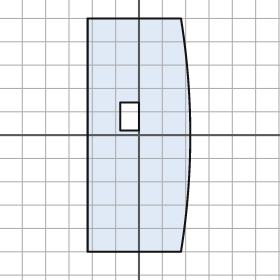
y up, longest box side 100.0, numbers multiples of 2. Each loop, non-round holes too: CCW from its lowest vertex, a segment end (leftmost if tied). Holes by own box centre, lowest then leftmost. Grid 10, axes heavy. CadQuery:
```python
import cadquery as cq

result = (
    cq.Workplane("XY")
    .moveTo(-22.0, -50.0)
    .lineTo(18.0, -50.0)
    .threePointArc((22.0, 0.0), (18.0, 50.0))
    .lineTo(-22.0, 50.0)
    .close()
    .moveTo(-8.0, 2.0)
    .lineTo(0.0, 2.0)
    .lineTo(0.0, 14.0)
    .lineTo(-8.0, 14.0)
    .close()
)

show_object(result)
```